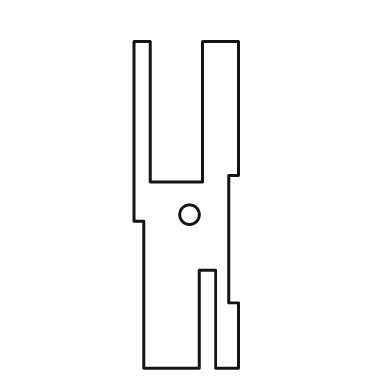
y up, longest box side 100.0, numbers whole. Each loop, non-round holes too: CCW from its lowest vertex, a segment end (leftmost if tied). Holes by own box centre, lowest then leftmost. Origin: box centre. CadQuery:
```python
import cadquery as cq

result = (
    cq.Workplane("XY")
    .moveTo(-13.0, -50.0)
    .lineTo(4.0, -50.0)
    .lineTo(4.0, -20.0)
    .lineTo(9.0, -20.0)
    .lineTo(9.0, -50.0)
    .lineTo(16.0, -50.0)
    .lineTo(16.0, -30.0)
    .lineTo(13.0, -30.0)
    .lineTo(13.0, 9.0)
    .lineTo(16.0, 9.0)
    .lineTo(16.0, 50.0)
    .lineTo(5.0, 50.0)
    .lineTo(5.0, 7.0)
    .lineTo(-11.0, 7.0)
    .lineTo(-11.0, 50.0)
    .lineTo(-16.0, 50.0)
    .lineTo(-16.0, -5.0)
    .lineTo(-13.0, -5.0)
    .close()
    .moveTo(1.0, -3.0)
    .circle(3.0)
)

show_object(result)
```